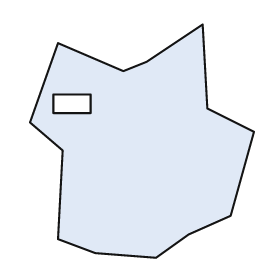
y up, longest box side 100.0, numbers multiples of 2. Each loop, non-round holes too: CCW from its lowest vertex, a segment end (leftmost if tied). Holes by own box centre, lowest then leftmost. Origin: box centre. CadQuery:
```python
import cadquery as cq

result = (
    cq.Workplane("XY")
    .moveTo(6.0, -50.0)
    .lineTo(20.0, -40.0)
    .lineTo(38.0, -32.0)
    .lineTo(48.0, 4.0)
    .lineTo(28.0, 14.0)
    .lineTo(26.0, 50.0)
    .lineTo(2.0, 34.0)
    .lineTo(-8.0, 30.0)
    .lineTo(-36.0, 42.0)
    .lineTo(-48.0, 8.0)
    .lineTo(-34.0, -4.0)
    .lineTo(-36.0, -42.0)
    .lineTo(-20.0, -48.0)
    .close()
    .moveTo(-38.0, 12.0)
    .lineTo(-22.0, 12.0)
    .lineTo(-22.0, 20.0)
    .lineTo(-38.0, 20.0)
    .close()
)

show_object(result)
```